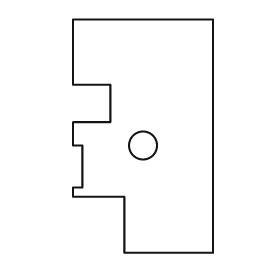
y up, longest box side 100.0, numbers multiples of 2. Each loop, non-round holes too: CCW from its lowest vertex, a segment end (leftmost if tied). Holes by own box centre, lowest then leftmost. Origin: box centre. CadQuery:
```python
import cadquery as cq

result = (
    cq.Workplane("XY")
    .moveTo(-8.0, -50.0)
    .lineTo(30.0, -50.0)
    .lineTo(30.0, 50.0)
    .lineTo(-30.0, 50.0)
    .lineTo(-30.0, 22.0)
    .lineTo(-14.0, 22.0)
    .lineTo(-14.0, 6.0)
    .lineTo(-30.0, 6.0)
    .lineTo(-30.0, -4.0)
    .lineTo(-26.0, -4.0)
    .lineTo(-26.0, -22.0)
    .lineTo(-30.0, -22.0)
    .lineTo(-30.0, -26.0)
    .lineTo(-8.0, -26.0)
    .close()
    .moveTo(0.0, -4.0)
    .circle(6.0)
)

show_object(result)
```